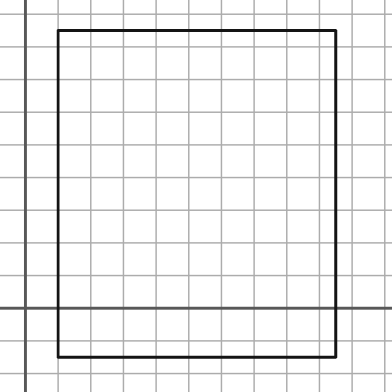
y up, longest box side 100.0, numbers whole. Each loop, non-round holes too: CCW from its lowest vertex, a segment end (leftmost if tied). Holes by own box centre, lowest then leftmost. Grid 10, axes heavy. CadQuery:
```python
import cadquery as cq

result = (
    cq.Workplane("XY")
    .moveTo(10.0, -15.0)
    .lineTo(95.0, -15.0)
    .lineTo(95.0, 85.0)
    .lineTo(10.0, 85.0)
    .close()
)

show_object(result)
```